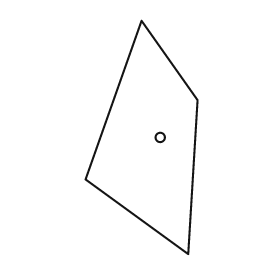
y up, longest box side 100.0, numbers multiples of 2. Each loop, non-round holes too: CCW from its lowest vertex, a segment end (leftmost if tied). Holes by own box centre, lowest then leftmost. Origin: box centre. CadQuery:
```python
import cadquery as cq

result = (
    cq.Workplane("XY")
    .moveTo(20.0, -50.0)
    .lineTo(24.0, 16.0)
    .lineTo(0.0, 50.0)
    .lineTo(-24.0, -18.0)
    .close()
    .moveTo(8.0, 0.0)
    .circle(2.0)
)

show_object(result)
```